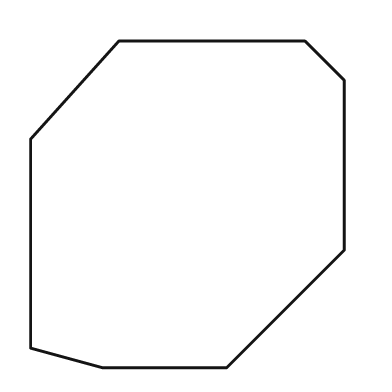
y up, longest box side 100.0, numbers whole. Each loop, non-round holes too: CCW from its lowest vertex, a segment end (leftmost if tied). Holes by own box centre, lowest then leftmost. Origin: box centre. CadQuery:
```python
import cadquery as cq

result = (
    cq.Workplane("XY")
    .moveTo(-26.0, -50.0)
    .lineTo(12.0, -50.0)
    .lineTo(48.0, -14.0)
    .lineTo(48.0, 38.0)
    .lineTo(36.0, 50.0)
    .lineTo(-21.0, 50.0)
    .lineTo(-48.0, 20.0)
    .lineTo(-48.0, -44.0)
    .close()
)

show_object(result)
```